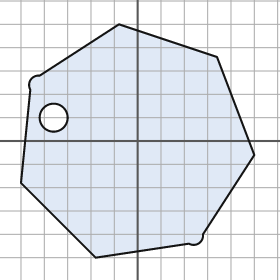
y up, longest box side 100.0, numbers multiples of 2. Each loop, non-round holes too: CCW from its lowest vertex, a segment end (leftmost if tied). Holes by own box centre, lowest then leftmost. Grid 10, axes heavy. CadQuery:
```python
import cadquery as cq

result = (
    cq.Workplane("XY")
    .moveTo(-18.0, -50.0)
    .lineTo(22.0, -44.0)
    .threePointArc((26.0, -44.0), (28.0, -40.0))
    .lineTo(50.0, -6.0)
    .lineTo(34.0, 36.0)
    .lineTo(-8.0, 50.0)
    .lineTo(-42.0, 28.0)
    .threePointArc((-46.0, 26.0), (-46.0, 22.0))
    .lineTo(-50.0, -18.0)
    .close()
    .moveTo(-36.0, 10.0)
    .circle(6.0)
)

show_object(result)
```